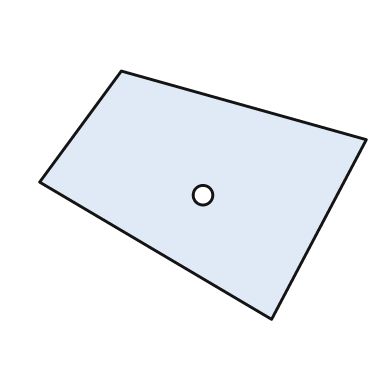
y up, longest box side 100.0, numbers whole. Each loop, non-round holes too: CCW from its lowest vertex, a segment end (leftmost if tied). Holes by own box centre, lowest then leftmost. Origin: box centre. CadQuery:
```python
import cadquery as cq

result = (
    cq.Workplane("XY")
    .moveTo(21.0, -38.0)
    .lineTo(50.0, 17.0)
    .lineTo(-25.0, 38.0)
    .lineTo(-50.0, 4.0)
    .close()
    .moveTo(0.0, 0.0)
    .circle(3.0)
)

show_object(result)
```